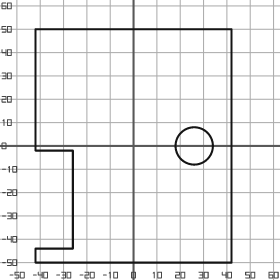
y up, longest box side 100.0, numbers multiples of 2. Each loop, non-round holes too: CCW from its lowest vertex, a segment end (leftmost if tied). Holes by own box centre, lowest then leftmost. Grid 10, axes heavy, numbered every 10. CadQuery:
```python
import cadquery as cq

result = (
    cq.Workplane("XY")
    .moveTo(-42.0, -50.0)
    .lineTo(42.0, -50.0)
    .lineTo(42.0, 50.0)
    .lineTo(-42.0, 50.0)
    .lineTo(-42.0, -2.0)
    .lineTo(-26.0, -2.0)
    .lineTo(-26.0, -44.0)
    .lineTo(-42.0, -44.0)
    .close()
    .moveTo(26.0, 0.0)
    .circle(8.0)
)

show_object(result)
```